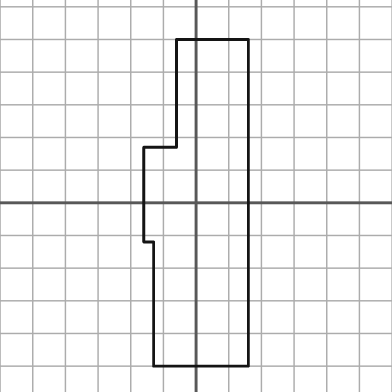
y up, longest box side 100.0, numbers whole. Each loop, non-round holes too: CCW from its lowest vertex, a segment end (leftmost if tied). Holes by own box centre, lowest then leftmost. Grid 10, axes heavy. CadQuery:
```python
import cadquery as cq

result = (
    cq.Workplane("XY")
    .moveTo(-13.0, -50.0)
    .lineTo(16.0, -50.0)
    .lineTo(16.0, 50.0)
    .lineTo(-6.0, 50.0)
    .lineTo(-6.0, 17.0)
    .lineTo(-16.0, 17.0)
    .lineTo(-16.0, -12.0)
    .lineTo(-13.0, -12.0)
    .close()
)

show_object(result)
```